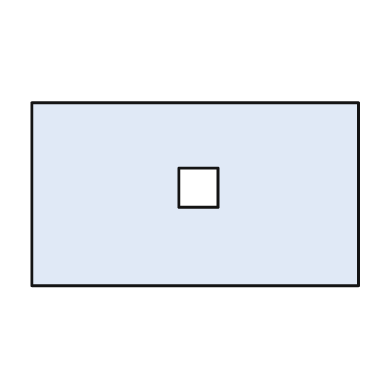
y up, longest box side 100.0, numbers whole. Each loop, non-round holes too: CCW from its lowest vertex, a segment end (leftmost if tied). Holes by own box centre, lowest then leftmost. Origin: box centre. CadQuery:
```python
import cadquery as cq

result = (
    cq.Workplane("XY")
    .moveTo(-50.0, -28.0)
    .lineTo(50.0, -28.0)
    .lineTo(50.0, 28.0)
    .lineTo(-50.0, 28.0)
    .close()
    .moveTo(-5.0, -4.0)
    .lineTo(7.0, -4.0)
    .lineTo(7.0, 8.0)
    .lineTo(-5.0, 8.0)
    .close()
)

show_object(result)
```